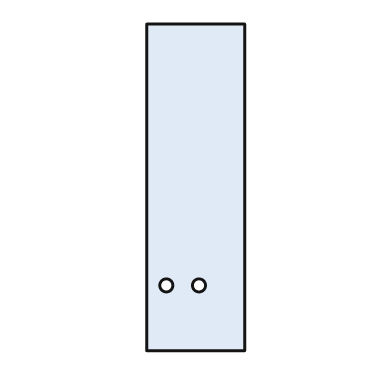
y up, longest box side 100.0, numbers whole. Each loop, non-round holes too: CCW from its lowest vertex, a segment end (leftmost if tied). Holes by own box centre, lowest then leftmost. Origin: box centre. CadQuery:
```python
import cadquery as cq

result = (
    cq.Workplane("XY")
    .moveTo(-15.0, -50.0)
    .lineTo(15.0, -50.0)
    .lineTo(15.0, 50.0)
    .lineTo(-15.0, 50.0)
    .close()
    .moveTo(-9.0, -30.0)
    .circle(2.0)
    .moveTo(1.0, -30.0)
    .circle(2.0)
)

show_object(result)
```